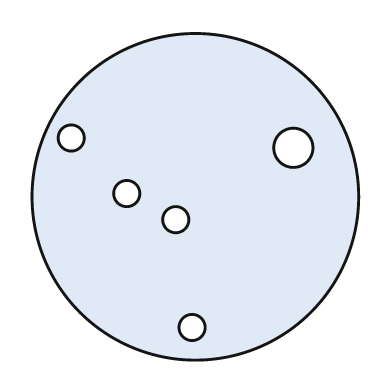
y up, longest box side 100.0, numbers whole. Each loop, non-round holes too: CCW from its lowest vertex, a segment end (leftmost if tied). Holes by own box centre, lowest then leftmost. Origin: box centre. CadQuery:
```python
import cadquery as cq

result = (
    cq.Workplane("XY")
    .moveTo(0.0, 0.0)
    .circle(50.0)
    .moveTo(-1.0, -40.0)
    .circle(4.0)
    .moveTo(-6.0, -7.0)
    .circle(4.0)
    .moveTo(-21.0, 1.0)
    .circle(4.0)
    .moveTo(30.0, 15.0)
    .circle(6.0)
    .moveTo(-38.0, 18.0)
    .circle(4.0)
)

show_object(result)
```